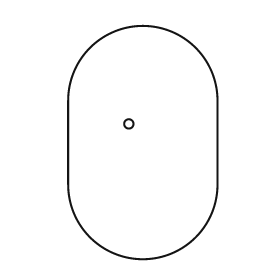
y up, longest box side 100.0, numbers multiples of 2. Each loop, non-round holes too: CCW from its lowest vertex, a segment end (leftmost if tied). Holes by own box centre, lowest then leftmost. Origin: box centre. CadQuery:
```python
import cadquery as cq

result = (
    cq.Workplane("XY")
    .moveTo(-32.0, -18.0)
    .threePointArc((0.0, -50.0), (32.0, -18.0))
    .lineTo(32.0, 18.0)
    .threePointArc((0.0, 50.0), (-32.0, 18.0))
    .close()
    .moveTo(-6.0, 8.0)
    .circle(2.0)
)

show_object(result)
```